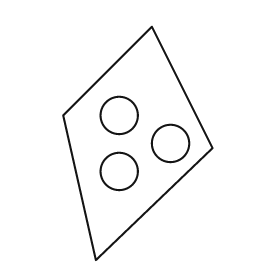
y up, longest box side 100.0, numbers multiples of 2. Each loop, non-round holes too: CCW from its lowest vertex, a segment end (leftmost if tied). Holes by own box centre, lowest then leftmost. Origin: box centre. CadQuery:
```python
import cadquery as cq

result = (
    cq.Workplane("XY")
    .moveTo(-18.0, -50.0)
    .lineTo(32.0, -2.0)
    .lineTo(6.0, 50.0)
    .lineTo(-32.0, 12.0)
    .close()
    .moveTo(-8.0, -12.0)
    .circle(8.0)
    .moveTo(14.0, 0.0)
    .circle(8.0)
    .moveTo(-8.0, 12.0)
    .circle(8.0)
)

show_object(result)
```